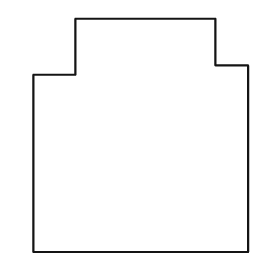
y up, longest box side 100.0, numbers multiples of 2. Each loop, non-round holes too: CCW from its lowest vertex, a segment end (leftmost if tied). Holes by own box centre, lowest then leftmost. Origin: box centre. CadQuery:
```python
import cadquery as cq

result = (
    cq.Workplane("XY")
    .moveTo(-46.0, -50.0)
    .lineTo(46.0, -50.0)
    .lineTo(46.0, 30.0)
    .lineTo(32.0, 30.0)
    .lineTo(32.0, 50.0)
    .lineTo(-28.0, 50.0)
    .lineTo(-28.0, 26.0)
    .lineTo(-46.0, 26.0)
    .close()
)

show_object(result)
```